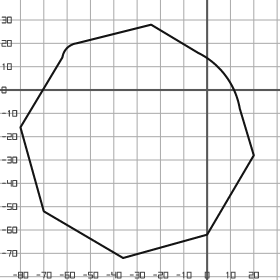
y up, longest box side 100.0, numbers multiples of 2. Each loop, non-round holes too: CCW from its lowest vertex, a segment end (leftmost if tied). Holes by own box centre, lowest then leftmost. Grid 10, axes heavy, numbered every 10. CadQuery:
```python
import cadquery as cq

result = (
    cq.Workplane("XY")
    .moveTo(-36.0, -72.0)
    .lineTo(0.0, -62.0)
    .lineTo(20.0, -28.0)
    .lineTo(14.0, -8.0)
    .threePointArc((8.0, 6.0), (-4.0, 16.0))
    .lineTo(-24.0, 28.0)
    .lineTo(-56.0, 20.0)
    .threePointArc((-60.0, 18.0), (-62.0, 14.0))
    .lineTo(-80.0, -16.0)
    .lineTo(-70.0, -52.0)
    .close()
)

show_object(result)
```